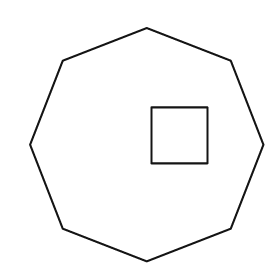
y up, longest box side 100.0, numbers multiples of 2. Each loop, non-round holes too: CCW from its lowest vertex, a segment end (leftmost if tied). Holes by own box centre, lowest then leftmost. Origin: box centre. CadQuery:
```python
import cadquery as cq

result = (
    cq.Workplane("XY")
    .moveTo(0.0, -50.0)
    .lineTo(36.0, -36.0)
    .lineTo(50.0, 0.0)
    .lineTo(36.0, 36.0)
    .lineTo(0.0, 50.0)
    .lineTo(-36.0, 36.0)
    .lineTo(-50.0, 0.0)
    .lineTo(-36.0, -36.0)
    .close()
    .moveTo(2.0, -8.0)
    .lineTo(26.0, -8.0)
    .lineTo(26.0, 16.0)
    .lineTo(2.0, 16.0)
    .close()
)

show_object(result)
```